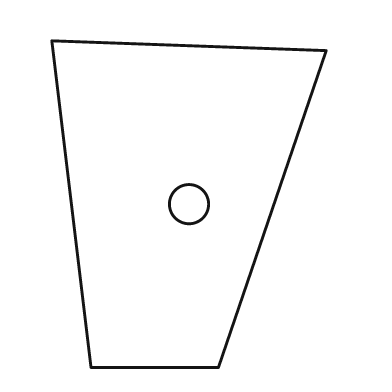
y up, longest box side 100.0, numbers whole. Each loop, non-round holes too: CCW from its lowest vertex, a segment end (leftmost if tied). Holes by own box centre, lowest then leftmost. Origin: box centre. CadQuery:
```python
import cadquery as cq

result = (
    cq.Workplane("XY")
    .moveTo(-30.0, -50.0)
    .lineTo(9.0, -50.0)
    .lineTo(42.0, 47.0)
    .lineTo(-42.0, 50.0)
    .close()
    .moveTo(0.0, 0.0)
    .circle(6.0)
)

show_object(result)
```